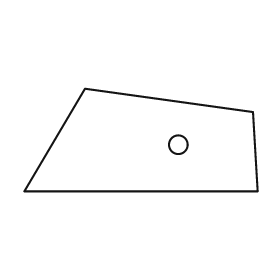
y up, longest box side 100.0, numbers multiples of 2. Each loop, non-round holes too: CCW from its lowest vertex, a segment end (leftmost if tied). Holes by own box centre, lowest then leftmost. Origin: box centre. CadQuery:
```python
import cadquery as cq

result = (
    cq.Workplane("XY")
    .moveTo(-50.0, -22.0)
    .lineTo(50.0, -22.0)
    .lineTo(48.0, 12.0)
    .lineTo(-24.0, 22.0)
    .close()
    .moveTo(16.0, -2.0)
    .circle(4.0)
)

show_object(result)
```